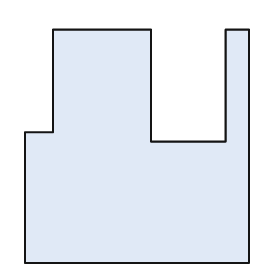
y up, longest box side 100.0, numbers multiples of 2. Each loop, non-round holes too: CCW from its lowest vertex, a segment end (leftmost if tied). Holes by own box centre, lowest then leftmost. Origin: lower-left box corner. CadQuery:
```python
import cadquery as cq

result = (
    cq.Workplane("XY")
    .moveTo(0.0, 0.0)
    .lineTo(96.0, 0.0)
    .lineTo(96.0, 100.0)
    .lineTo(86.0, 100.0)
    .lineTo(86.0, 52.0)
    .lineTo(54.0, 52.0)
    .lineTo(54.0, 100.0)
    .lineTo(12.0, 100.0)
    .lineTo(12.0, 56.0)
    .lineTo(0.0, 56.0)
    .close()
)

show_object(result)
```